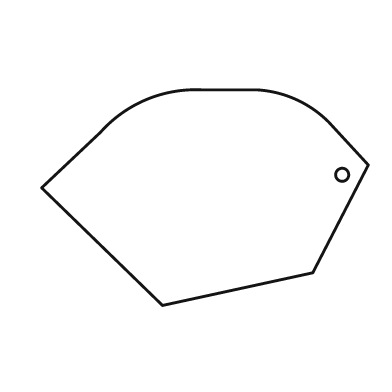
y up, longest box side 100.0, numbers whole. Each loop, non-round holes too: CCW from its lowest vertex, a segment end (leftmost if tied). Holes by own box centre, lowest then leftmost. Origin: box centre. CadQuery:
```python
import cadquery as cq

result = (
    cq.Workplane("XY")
    .moveTo(-13.0, -33.0)
    .lineTo(33.0, -23.0)
    .lineTo(50.0, 10.0)
    .lineTo(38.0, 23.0)
    .threePointArc((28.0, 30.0), (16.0, 33.0))
    .lineTo(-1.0, 33.0)
    .threePointArc((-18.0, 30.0), (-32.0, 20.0))
    .lineTo(-50.0, 3.0)
    .close()
    .moveTo(42.0, 7.0)
    .circle(2.0)
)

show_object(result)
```